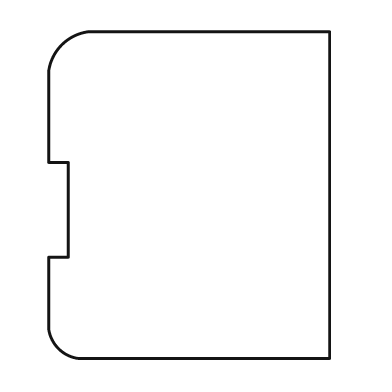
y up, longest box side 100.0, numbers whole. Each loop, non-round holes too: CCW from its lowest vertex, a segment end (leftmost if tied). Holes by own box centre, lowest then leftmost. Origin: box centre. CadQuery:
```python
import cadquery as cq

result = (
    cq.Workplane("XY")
    .moveTo(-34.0, -50.0)
    .lineTo(43.0, -50.0)
    .lineTo(43.0, 50.0)
    .lineTo(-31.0, 50.0)
    .threePointArc((-39.0, 46.0), (-43.0, 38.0))
    .lineTo(-43.0, 10.0)
    .lineTo(-37.0, 10.0)
    .lineTo(-37.0, -19.0)
    .lineTo(-43.0, -19.0)
    .lineTo(-43.0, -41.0)
    .threePointArc((-40.0, -47.0), (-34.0, -50.0))
    .close()
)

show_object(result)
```